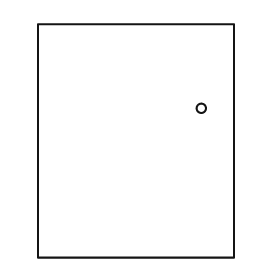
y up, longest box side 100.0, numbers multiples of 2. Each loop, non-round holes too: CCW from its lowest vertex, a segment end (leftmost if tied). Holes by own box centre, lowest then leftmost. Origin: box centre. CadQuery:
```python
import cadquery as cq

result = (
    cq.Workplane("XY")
    .moveTo(-42.0, -50.0)
    .lineTo(42.0, -50.0)
    .lineTo(42.0, 50.0)
    .lineTo(-42.0, 50.0)
    .close()
    .moveTo(28.0, 14.0)
    .circle(2.0)
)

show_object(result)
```